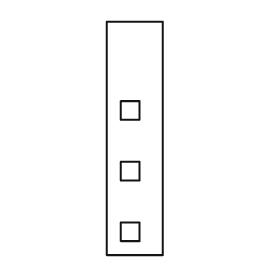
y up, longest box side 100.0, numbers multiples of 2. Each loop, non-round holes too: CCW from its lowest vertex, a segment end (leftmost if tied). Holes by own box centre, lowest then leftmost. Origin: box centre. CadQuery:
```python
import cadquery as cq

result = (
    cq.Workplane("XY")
    .moveTo(-12.0, -50.0)
    .lineTo(12.0, -50.0)
    .lineTo(12.0, 50.0)
    .lineTo(-12.0, 50.0)
    .close()
    .moveTo(-6.0, -44.0)
    .lineTo(2.0, -44.0)
    .lineTo(2.0, -36.0)
    .lineTo(-6.0, -36.0)
    .close()
    .moveTo(-6.0, -18.0)
    .lineTo(2.0, -18.0)
    .lineTo(2.0, -10.0)
    .lineTo(-6.0, -10.0)
    .close()
    .moveTo(-6.0, 8.0)
    .lineTo(2.0, 8.0)
    .lineTo(2.0, 16.0)
    .lineTo(-6.0, 16.0)
    .close()
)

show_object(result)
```